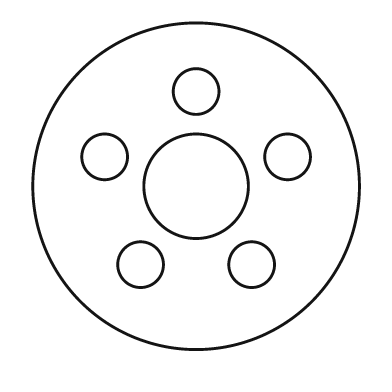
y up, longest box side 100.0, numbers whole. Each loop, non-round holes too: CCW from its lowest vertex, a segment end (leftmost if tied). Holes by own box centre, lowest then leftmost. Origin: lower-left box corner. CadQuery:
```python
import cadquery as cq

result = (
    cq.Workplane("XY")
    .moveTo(50.0, 50.0)
    .circle(50.0)
    .moveTo(33.0, 26.0)
    .circle(7.0)
    .moveTo(67.0, 26.0)
    .circle(7.0)
    .moveTo(50.0, 50.0)
    .circle(16.0)
    .moveTo(22.0, 59.0)
    .circle(7.0)
    .moveTo(78.0, 59.0)
    .circle(7.0)
    .moveTo(50.0, 79.0)
    .circle(7.0)
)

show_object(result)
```